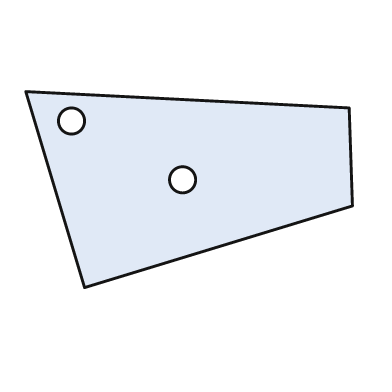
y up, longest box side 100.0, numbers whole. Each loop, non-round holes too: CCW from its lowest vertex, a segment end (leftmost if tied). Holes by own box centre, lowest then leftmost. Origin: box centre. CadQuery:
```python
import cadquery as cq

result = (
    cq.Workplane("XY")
    .moveTo(-32.0, -30.0)
    .lineTo(50.0, -5.0)
    .lineTo(49.0, 25.0)
    .lineTo(-50.0, 30.0)
    .close()
    .moveTo(-2.0, 3.0)
    .circle(4.0)
    .moveTo(-36.0, 21.0)
    .circle(4.0)
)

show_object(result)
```